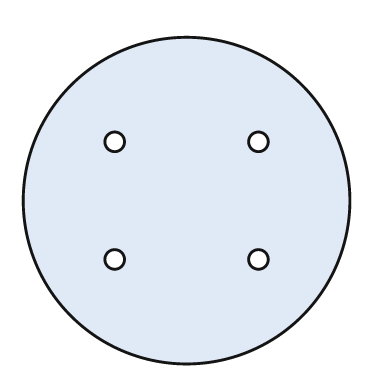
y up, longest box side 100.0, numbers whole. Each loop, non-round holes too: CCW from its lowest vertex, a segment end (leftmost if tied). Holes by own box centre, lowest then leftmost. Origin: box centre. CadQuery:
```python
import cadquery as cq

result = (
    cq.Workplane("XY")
    .moveTo(0.0, 0.0)
    .circle(50.0)
    .moveTo(-22.0, -18.0)
    .circle(3.0)
    .moveTo(22.0, -18.0)
    .circle(3.0)
    .moveTo(-22.0, 18.0)
    .circle(3.0)
    .moveTo(22.0, 18.0)
    .circle(3.0)
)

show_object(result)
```